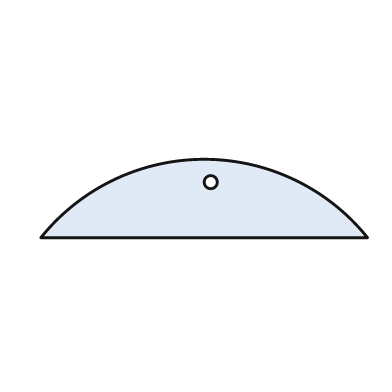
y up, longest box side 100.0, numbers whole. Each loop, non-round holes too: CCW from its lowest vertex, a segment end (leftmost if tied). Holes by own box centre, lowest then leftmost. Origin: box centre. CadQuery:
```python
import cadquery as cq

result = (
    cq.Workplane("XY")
    .moveTo(-50.0, -12.0)
    .lineTo(50.0, -12.0)
    .threePointArc((0.0, 12.0), (-50.0, -12.0))
    .close()
    .moveTo(2.0, 5.0)
    .circle(2.0)
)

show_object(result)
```